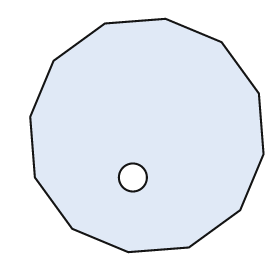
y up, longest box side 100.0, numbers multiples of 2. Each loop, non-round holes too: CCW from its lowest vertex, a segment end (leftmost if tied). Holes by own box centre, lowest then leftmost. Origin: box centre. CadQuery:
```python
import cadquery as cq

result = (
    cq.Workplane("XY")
    .moveTo(-8.0, -50.0)
    .lineTo(18.0, -48.0)
    .lineTo(40.0, -32.0)
    .lineTo(50.0, -8.0)
    .lineTo(48.0, 18.0)
    .lineTo(32.0, 40.0)
    .lineTo(8.0, 50.0)
    .lineTo(-18.0, 48.0)
    .lineTo(-40.0, 32.0)
    .lineTo(-50.0, 8.0)
    .lineTo(-48.0, -18.0)
    .lineTo(-32.0, -40.0)
    .close()
    .moveTo(-6.0, -18.0)
    .circle(6.0)
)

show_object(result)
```